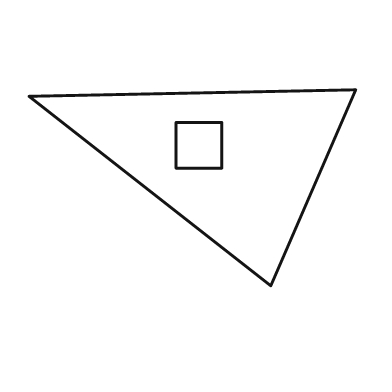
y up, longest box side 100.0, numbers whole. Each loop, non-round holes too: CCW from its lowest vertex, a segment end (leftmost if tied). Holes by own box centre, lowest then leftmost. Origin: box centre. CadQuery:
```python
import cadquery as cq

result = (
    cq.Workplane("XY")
    .moveTo(24.0, -30.0)
    .lineTo(50.0, 30.0)
    .lineTo(-50.0, 28.0)
    .close()
    .moveTo(-5.0, 6.0)
    .lineTo(9.0, 6.0)
    .lineTo(9.0, 20.0)
    .lineTo(-5.0, 20.0)
    .close()
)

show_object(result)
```